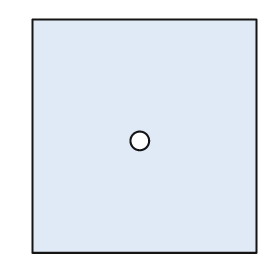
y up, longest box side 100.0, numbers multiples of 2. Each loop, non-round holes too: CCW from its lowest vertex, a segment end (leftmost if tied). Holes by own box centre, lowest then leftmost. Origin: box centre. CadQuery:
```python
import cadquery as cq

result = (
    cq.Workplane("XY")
    .moveTo(-48.0, -50.0)
    .lineTo(48.0, -50.0)
    .lineTo(48.0, 50.0)
    .lineTo(-48.0, 50.0)
    .close()
    .moveTo(-2.0, -2.0)
    .circle(4.0)
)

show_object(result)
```